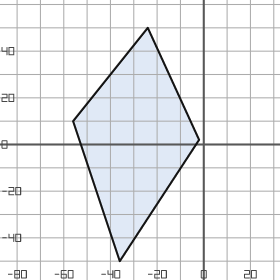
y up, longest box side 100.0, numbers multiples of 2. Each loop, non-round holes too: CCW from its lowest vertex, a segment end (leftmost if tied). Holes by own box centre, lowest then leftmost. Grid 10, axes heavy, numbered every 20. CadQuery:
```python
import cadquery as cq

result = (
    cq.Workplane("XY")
    .moveTo(-36.0, -50.0)
    .lineTo(-2.0, 2.0)
    .lineTo(-24.0, 50.0)
    .lineTo(-56.0, 10.0)
    .close()
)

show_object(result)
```